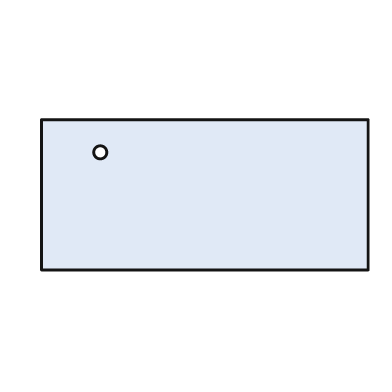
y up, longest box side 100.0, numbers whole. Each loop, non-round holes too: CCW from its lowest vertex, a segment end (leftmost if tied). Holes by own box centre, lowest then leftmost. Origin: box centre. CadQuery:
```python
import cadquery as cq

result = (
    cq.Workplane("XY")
    .moveTo(-50.0, -23.0)
    .lineTo(50.0, -23.0)
    .lineTo(50.0, 23.0)
    .lineTo(-50.0, 23.0)
    .close()
    .moveTo(-32.0, 13.0)
    .circle(2.0)
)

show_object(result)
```